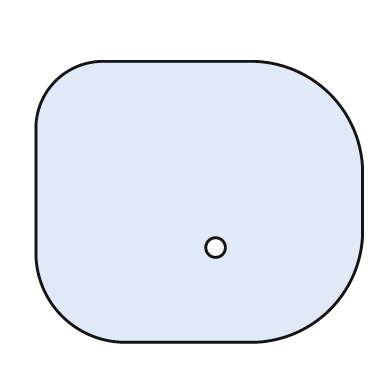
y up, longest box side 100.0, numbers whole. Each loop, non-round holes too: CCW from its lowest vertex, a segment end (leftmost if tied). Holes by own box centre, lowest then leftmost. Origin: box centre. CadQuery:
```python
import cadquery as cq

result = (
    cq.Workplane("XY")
    .moveTo(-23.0, -43.0)
    .lineTo(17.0, -43.0)
    .threePointArc((40.0, -33.0), (50.0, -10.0))
    .lineTo(50.0, 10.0)
    .threePointArc((40.0, 33.0), (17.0, 43.0))
    .lineTo(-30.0, 43.0)
    .threePointArc((-44.0, 37.0), (-50.0, 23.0))
    .lineTo(-50.0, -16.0)
    .threePointArc((-42.0, -35.0), (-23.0, -43.0))
    .close()
    .moveTo(5.0, -14.0)
    .circle(3.0)
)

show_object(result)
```